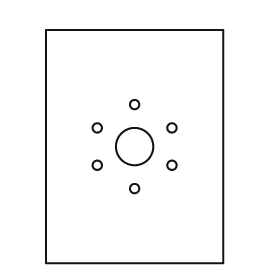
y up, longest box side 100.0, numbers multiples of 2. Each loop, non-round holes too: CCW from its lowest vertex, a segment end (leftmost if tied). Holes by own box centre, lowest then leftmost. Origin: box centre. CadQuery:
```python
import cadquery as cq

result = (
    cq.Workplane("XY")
    .moveTo(-38.0, -50.0)
    .lineTo(38.0, -50.0)
    .lineTo(38.0, 50.0)
    .lineTo(-38.0, 50.0)
    .close()
    .moveTo(0.0, -18.0)
    .circle(2.0)
    .moveTo(-16.0, -8.0)
    .circle(2.0)
    .moveTo(16.0, -8.0)
    .circle(2.0)
    .moveTo(0.0, 0.0)
    .circle(8.0)
    .moveTo(-16.0, 8.0)
    .circle(2.0)
    .moveTo(16.0, 8.0)
    .circle(2.0)
    .moveTo(0.0, 18.0)
    .circle(2.0)
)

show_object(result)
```